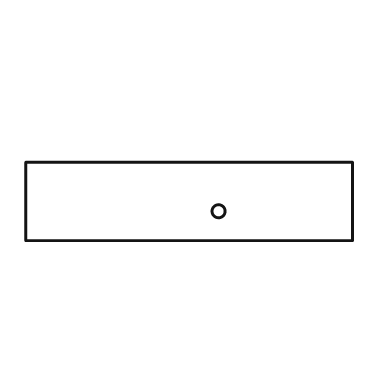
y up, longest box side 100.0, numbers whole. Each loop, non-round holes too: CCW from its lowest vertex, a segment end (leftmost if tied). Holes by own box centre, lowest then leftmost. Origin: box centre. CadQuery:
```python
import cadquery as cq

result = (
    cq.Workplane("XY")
    .moveTo(-50.0, -12.0)
    .lineTo(50.0, -12.0)
    .lineTo(50.0, 12.0)
    .lineTo(-50.0, 12.0)
    .close()
    .moveTo(9.0, -3.0)
    .circle(2.0)
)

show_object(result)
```